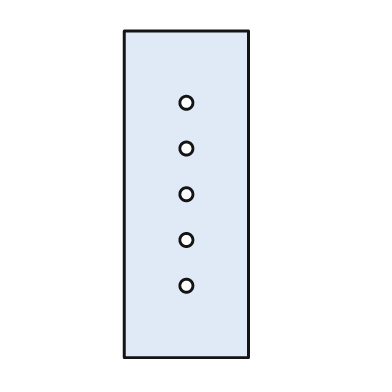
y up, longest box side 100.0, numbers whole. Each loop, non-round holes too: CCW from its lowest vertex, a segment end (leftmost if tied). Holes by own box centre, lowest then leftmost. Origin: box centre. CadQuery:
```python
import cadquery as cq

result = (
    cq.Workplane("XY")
    .moveTo(-19.0, -50.0)
    .lineTo(19.0, -50.0)
    .lineTo(19.0, 50.0)
    .lineTo(-19.0, 50.0)
    .close()
    .moveTo(0.0, -28.0)
    .circle(2.0)
    .moveTo(0.0, -14.0)
    .circle(2.0)
    .moveTo(0.0, 0.0)
    .circle(2.0)
    .moveTo(0.0, 14.0)
    .circle(2.0)
    .moveTo(0.0, 28.0)
    .circle(2.0)
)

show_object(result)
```